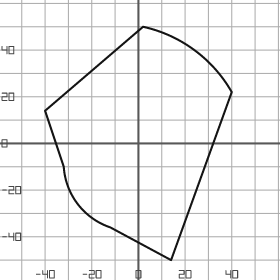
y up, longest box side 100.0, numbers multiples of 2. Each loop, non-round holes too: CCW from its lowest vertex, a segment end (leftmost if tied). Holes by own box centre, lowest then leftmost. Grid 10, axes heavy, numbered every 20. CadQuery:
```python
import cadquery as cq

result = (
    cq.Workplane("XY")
    .moveTo(14.0, -50.0)
    .lineTo(40.0, 22.0)
    .threePointArc((24.0, 40.0), (2.0, 50.0))
    .lineTo(-40.0, 14.0)
    .lineTo(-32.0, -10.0)
    .threePointArc((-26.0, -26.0), (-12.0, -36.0))
    .close()
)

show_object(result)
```